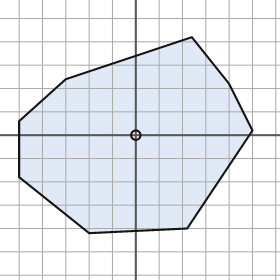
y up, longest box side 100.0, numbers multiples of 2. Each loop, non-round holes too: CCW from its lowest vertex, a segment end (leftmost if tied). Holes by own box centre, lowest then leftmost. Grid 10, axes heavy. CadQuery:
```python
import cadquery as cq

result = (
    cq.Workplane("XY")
    .moveTo(-20.0, -42.0)
    .lineTo(22.0, -40.0)
    .lineTo(50.0, 2.0)
    .lineTo(40.0, 22.0)
    .lineTo(24.0, 42.0)
    .lineTo(-30.0, 24.0)
    .lineTo(-50.0, 6.0)
    .lineTo(-50.0, -18.0)
    .close()
    .moveTo(0.0, 0.0)
    .circle(2.0)
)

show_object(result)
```